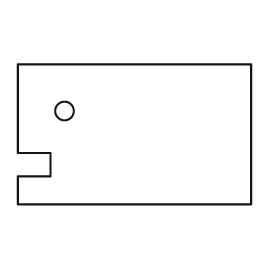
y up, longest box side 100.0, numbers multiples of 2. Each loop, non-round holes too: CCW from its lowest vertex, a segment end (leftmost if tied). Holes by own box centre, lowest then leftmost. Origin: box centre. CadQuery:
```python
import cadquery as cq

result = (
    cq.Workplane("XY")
    .moveTo(-50.0, -30.0)
    .lineTo(50.0, -30.0)
    .lineTo(50.0, 30.0)
    .lineTo(-50.0, 30.0)
    .lineTo(-50.0, -8.0)
    .lineTo(-36.0, -8.0)
    .lineTo(-36.0, -18.0)
    .lineTo(-50.0, -18.0)
    .close()
    .moveTo(-30.0, 10.0)
    .circle(4.0)
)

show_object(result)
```